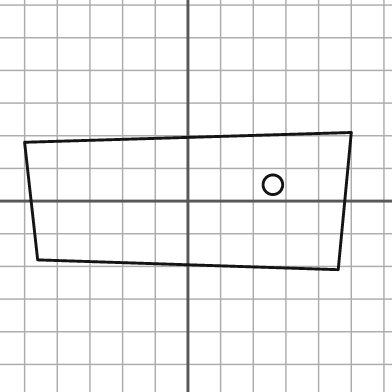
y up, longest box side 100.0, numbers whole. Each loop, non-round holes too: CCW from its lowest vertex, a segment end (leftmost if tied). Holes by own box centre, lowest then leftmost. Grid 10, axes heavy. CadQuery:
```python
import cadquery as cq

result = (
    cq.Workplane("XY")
    .moveTo(46.0, -21.0)
    .lineTo(50.0, 21.0)
    .lineTo(-50.0, 18.0)
    .lineTo(-46.0, -18.0)
    .close()
    .moveTo(26.0, 5.0)
    .circle(3.0)
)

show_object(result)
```